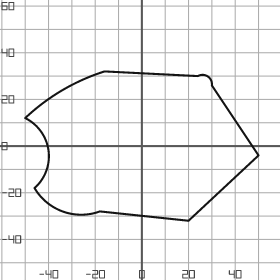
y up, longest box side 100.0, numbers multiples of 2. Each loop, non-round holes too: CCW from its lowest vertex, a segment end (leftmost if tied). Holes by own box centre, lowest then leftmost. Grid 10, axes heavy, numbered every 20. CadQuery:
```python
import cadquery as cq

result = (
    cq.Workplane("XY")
    .moveTo(20.0, -32.0)
    .lineTo(50.0, -4.0)
    .lineTo(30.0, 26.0)
    .threePointArc((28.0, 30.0), (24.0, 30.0))
    .lineTo(-16.0, 32.0)
    .threePointArc((-34.0, 24.0), (-50.0, 12.0))
    .threePointArc((-40.0, -2.0), (-46.0, -18.0))
    .threePointArc((-34.0, -28.0), (-18.0, -28.0))
    .close()
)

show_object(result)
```